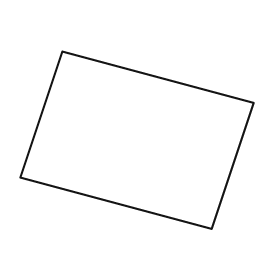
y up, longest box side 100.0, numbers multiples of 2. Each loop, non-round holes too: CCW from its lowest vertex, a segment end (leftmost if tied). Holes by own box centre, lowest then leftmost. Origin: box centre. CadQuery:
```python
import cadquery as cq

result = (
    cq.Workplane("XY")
    .moveTo(32.0, -38.0)
    .lineTo(50.0, 16.0)
    .lineTo(-32.0, 38.0)
    .lineTo(-50.0, -16.0)
    .close()
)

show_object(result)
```